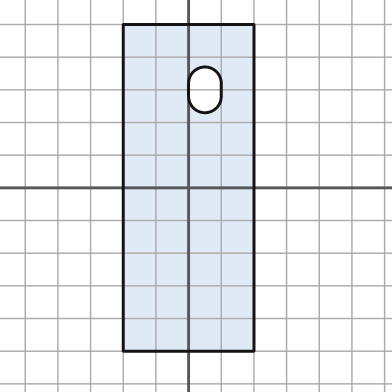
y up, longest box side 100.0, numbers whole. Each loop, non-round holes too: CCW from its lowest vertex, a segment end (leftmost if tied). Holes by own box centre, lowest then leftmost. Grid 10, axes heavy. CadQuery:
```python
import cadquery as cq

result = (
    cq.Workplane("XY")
    .moveTo(-20.0, -50.0)
    .lineTo(20.0, -50.0)
    .lineTo(20.0, 50.0)
    .lineTo(-20.0, 50.0)
    .close()
    .moveTo(0.0, 28.0)
    .threePointArc((5.0, 23.0), (10.0, 28.0))
    .lineTo(10.0, 32.0)
    .threePointArc((5.0, 37.0), (0.0, 32.0))
    .close()
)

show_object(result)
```